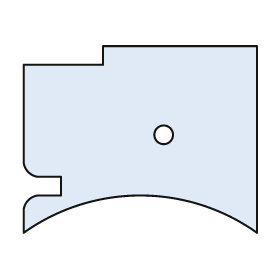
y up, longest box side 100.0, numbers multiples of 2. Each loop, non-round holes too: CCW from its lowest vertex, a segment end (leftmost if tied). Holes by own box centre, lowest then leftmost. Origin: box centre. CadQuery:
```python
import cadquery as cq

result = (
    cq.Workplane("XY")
    .moveTo(-50.0, -40.0)
    .threePointArc((0.0, -24.0), (50.0, -40.0))
    .lineTo(50.0, 40.0)
    .lineTo(-16.0, 40.0)
    .lineTo(-16.0, 32.0)
    .lineTo(-50.0, 32.0)
    .lineTo(-50.0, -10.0)
    .threePointArc((-48.0, -14.0), (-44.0, -16.0))
    .lineTo(-34.0, -16.0)
    .lineTo(-34.0, -24.0)
    .lineTo(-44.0, -24.0)
    .threePointArc((-48.0, -26.0), (-50.0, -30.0))
    .close()
    .moveTo(10.0, 2.0)
    .circle(4.0)
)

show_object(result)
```